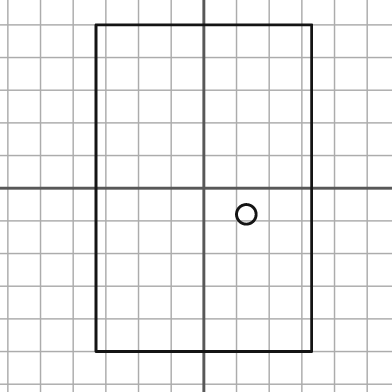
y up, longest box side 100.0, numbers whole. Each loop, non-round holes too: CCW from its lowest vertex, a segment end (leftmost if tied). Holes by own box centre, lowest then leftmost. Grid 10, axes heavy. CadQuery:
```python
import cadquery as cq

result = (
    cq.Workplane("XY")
    .moveTo(-33.0, -50.0)
    .lineTo(33.0, -50.0)
    .lineTo(33.0, 50.0)
    .lineTo(-33.0, 50.0)
    .close()
    .moveTo(13.0, -8.0)
    .circle(3.0)
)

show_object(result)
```